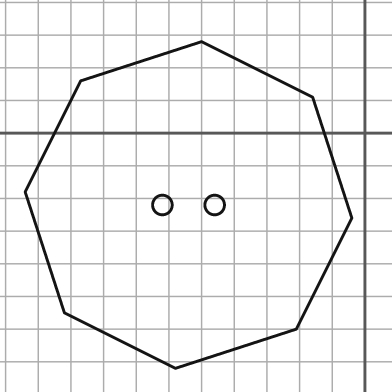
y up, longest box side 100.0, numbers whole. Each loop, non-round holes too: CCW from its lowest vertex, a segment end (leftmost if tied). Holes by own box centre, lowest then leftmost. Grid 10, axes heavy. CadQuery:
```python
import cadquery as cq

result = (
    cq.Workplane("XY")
    .moveTo(-58.0, -72.0)
    .lineTo(-21.0, -60.0)
    .lineTo(-4.0, -26.0)
    .lineTo(-16.0, 11.0)
    .lineTo(-50.0, 28.0)
    .lineTo(-87.0, 16.0)
    .lineTo(-104.0, -18.0)
    .lineTo(-92.0, -55.0)
    .close()
    .moveTo(-62.0, -22.0)
    .circle(3.0)
    .moveTo(-46.0, -22.0)
    .circle(3.0)
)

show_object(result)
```